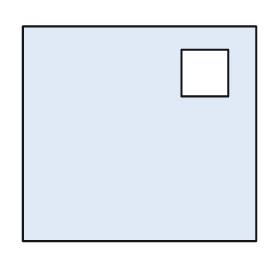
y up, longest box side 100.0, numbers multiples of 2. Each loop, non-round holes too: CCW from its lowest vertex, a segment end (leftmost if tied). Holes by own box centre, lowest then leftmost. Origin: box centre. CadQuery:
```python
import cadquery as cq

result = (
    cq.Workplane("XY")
    .moveTo(-50.0, -46.0)
    .lineTo(50.0, -46.0)
    .lineTo(50.0, 46.0)
    .lineTo(-50.0, 46.0)
    .close()
    .moveTo(18.0, 16.0)
    .lineTo(38.0, 16.0)
    .lineTo(38.0, 36.0)
    .lineTo(18.0, 36.0)
    .close()
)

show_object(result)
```